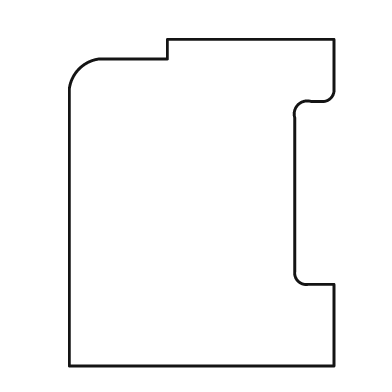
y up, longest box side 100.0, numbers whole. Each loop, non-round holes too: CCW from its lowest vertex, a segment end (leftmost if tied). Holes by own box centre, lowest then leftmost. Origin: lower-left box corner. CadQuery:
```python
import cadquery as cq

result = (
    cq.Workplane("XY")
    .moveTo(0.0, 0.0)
    .lineTo(81.0, 0.0)
    .lineTo(81.0, 25.0)
    .lineTo(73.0, 25.0)
    .threePointArc((70.0, 26.0), (69.0, 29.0))
    .lineTo(69.0, 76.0)
    .threePointArc((70.0, 80.0), (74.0, 81.0))
    .lineTo(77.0, 81.0)
    .threePointArc((80.0, 82.0), (81.0, 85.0))
    .lineTo(81.0, 100.0)
    .lineTo(30.0, 100.0)
    .lineTo(30.0, 94.0)
    .lineTo(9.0, 94.0)
    .threePointArc((3.0, 91.0), (0.0, 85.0))
    .close()
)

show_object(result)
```